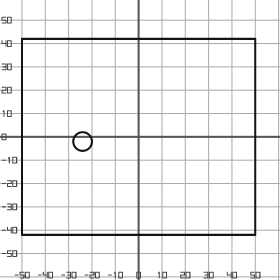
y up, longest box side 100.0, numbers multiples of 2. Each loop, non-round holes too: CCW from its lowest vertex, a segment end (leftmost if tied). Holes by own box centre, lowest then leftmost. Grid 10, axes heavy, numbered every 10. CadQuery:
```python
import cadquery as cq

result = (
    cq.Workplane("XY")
    .moveTo(-50.0, -42.0)
    .lineTo(50.0, -42.0)
    .lineTo(50.0, 42.0)
    .lineTo(-50.0, 42.0)
    .close()
    .moveTo(-24.0, -2.0)
    .circle(4.0)
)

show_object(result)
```